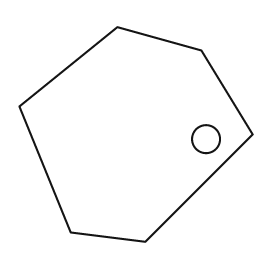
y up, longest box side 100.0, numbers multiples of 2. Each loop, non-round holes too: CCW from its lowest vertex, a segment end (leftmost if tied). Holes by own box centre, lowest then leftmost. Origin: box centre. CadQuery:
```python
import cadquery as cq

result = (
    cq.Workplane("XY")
    .moveTo(4.0, -46.0)
    .lineTo(50.0, 0.0)
    .lineTo(28.0, 36.0)
    .lineTo(-8.0, 46.0)
    .lineTo(-50.0, 12.0)
    .lineTo(-28.0, -42.0)
    .close()
    .moveTo(30.0, -2.0)
    .circle(6.0)
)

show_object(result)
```